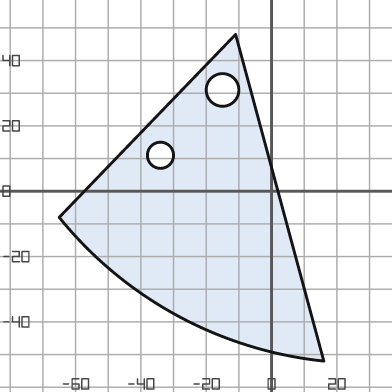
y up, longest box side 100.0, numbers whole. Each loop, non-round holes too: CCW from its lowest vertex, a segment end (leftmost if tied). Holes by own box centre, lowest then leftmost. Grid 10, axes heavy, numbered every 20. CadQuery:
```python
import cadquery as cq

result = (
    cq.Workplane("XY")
    .moveTo(16.0, -52.0)
    .lineTo(-11.0, 48.0)
    .lineTo(-65.0, -8.0)
    .threePointArc((-29.0, -38.0), (16.0, -52.0))
    .close()
    .moveTo(-34.0, 11.0)
    .circle(4.0)
    .moveTo(-15.0, 31.0)
    .circle(5.0)
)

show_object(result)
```